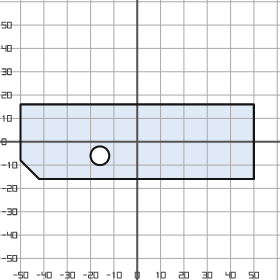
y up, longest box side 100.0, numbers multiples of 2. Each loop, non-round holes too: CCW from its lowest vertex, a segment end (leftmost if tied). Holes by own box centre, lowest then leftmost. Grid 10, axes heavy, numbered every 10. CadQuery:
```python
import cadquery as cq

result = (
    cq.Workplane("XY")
    .moveTo(-42.0, -16.0)
    .lineTo(50.0, -16.0)
    .lineTo(50.0, 16.0)
    .lineTo(-50.0, 16.0)
    .lineTo(-50.0, -8.0)
    .close()
    .moveTo(-16.0, -6.0)
    .circle(4.0)
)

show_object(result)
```